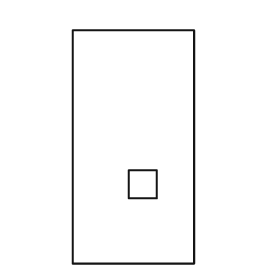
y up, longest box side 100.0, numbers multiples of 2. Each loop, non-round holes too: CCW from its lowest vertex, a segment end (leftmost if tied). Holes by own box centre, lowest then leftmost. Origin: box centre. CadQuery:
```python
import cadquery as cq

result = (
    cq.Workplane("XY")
    .moveTo(-26.0, -50.0)
    .lineTo(26.0, -50.0)
    .lineTo(26.0, 50.0)
    .lineTo(-26.0, 50.0)
    .close()
    .moveTo(-2.0, -22.0)
    .lineTo(10.0, -22.0)
    .lineTo(10.0, -10.0)
    .lineTo(-2.0, -10.0)
    .close()
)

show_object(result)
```